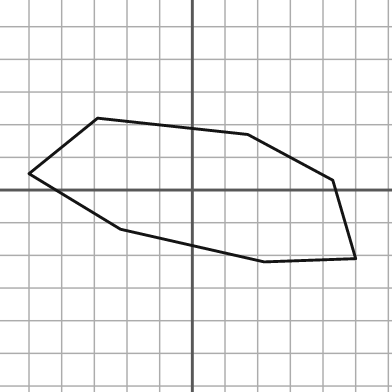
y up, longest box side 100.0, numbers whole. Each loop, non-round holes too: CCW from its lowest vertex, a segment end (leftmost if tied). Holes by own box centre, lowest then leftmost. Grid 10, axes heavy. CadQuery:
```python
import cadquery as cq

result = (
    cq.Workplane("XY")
    .moveTo(22.0, -22.0)
    .lineTo(50.0, -21.0)
    .lineTo(43.0, 3.0)
    .lineTo(17.0, 17.0)
    .lineTo(-29.0, 22.0)
    .lineTo(-50.0, 5.0)
    .lineTo(-22.0, -12.0)
    .close()
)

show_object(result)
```